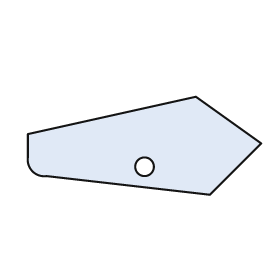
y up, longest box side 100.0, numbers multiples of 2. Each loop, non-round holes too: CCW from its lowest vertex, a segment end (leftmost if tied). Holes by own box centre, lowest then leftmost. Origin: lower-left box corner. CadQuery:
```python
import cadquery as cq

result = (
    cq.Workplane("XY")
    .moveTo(78.0, 0.0)
    .lineTo(100.0, 22.0)
    .lineTo(72.0, 42.0)
    .lineTo(0.0, 26.0)
    .lineTo(0.0, 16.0)
    .threePointArc((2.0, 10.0), (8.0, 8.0))
    .close()
    .moveTo(50.0, 12.0)
    .circle(4.0)
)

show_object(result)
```